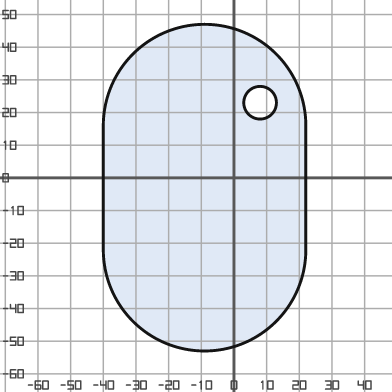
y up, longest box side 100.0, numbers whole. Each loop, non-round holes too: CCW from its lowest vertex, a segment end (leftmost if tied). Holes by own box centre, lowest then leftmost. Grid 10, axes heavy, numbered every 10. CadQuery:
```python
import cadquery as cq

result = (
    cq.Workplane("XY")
    .moveTo(-40.0, -22.0)
    .threePointArc((-9.0, -53.0), (22.0, -22.0))
    .lineTo(22.0, 16.0)
    .threePointArc((-9.0, 47.0), (-40.0, 16.0))
    .close()
    .moveTo(8.0, 23.0)
    .circle(5.0)
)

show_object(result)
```